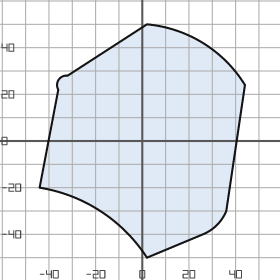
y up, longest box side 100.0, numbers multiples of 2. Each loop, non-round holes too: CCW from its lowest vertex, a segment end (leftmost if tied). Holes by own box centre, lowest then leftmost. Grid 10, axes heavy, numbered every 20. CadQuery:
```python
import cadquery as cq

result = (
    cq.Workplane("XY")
    .moveTo(2.0, -50.0)
    .lineTo(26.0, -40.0)
    .threePointArc((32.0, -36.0), (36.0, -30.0))
    .lineTo(44.0, 24.0)
    .threePointArc((26.0, 42.0), (2.0, 50.0))
    .lineTo(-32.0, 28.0)
    .threePointArc((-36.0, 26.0), (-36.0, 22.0))
    .lineTo(-44.0, -20.0)
    .threePointArc((-18.0, -30.0), (2.0, -50.0))
    .close()
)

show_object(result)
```